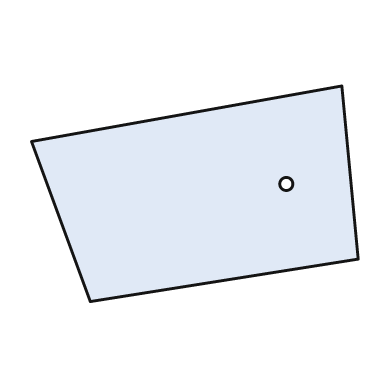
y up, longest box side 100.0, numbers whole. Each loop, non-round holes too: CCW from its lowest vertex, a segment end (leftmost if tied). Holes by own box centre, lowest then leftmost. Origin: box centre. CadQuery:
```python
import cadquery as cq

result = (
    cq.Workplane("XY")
    .moveTo(-32.0, -33.0)
    .lineTo(50.0, -20.0)
    .lineTo(45.0, 33.0)
    .lineTo(-50.0, 16.0)
    .close()
    .moveTo(28.0, 3.0)
    .circle(2.0)
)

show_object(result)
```